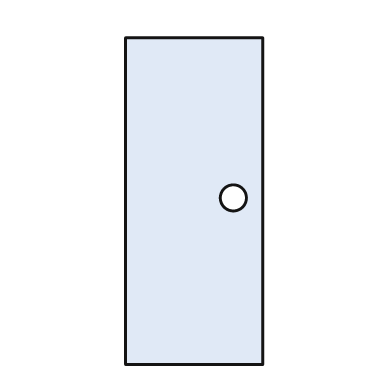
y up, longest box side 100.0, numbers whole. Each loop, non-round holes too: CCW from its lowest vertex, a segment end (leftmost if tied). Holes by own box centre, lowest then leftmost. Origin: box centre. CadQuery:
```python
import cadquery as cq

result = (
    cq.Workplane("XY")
    .moveTo(-21.0, -50.0)
    .lineTo(21.0, -50.0)
    .lineTo(21.0, 50.0)
    .lineTo(-21.0, 50.0)
    .close()
    .moveTo(12.0, 1.0)
    .circle(4.0)
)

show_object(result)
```